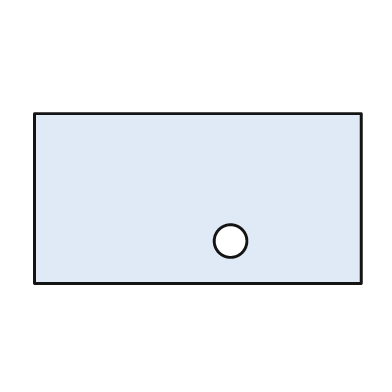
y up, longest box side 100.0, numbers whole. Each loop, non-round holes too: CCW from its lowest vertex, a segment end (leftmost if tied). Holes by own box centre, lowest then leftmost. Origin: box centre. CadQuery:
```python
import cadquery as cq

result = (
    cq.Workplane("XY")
    .moveTo(-50.0, -26.0)
    .lineTo(50.0, -26.0)
    .lineTo(50.0, 26.0)
    .lineTo(-50.0, 26.0)
    .close()
    .moveTo(10.0, -13.0)
    .circle(5.0)
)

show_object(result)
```